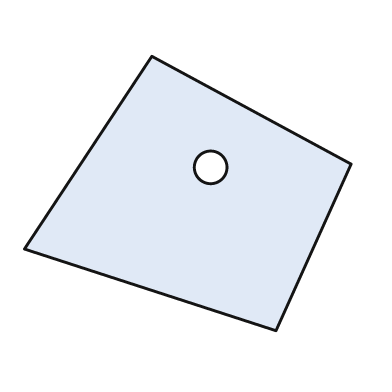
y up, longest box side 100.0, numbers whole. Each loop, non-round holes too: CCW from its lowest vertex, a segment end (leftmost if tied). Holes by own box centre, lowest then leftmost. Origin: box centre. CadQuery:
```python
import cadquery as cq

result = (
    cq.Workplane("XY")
    .moveTo(27.0, -42.0)
    .lineTo(50.0, 9.0)
    .lineTo(-11.0, 42.0)
    .lineTo(-50.0, -17.0)
    .close()
    .moveTo(7.0, 8.0)
    .circle(5.0)
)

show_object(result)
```